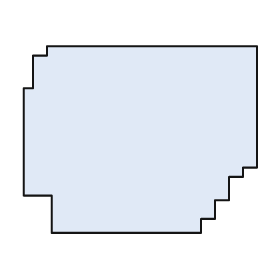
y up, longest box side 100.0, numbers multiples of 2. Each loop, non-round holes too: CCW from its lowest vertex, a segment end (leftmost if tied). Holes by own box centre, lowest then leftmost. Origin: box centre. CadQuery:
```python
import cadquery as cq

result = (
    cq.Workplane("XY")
    .moveTo(-38.0, -40.0)
    .lineTo(26.0, -40.0)
    .lineTo(26.0, -34.0)
    .lineTo(32.0, -34.0)
    .lineTo(32.0, -26.0)
    .lineTo(38.0, -26.0)
    .lineTo(38.0, -16.0)
    .lineTo(44.0, -16.0)
    .lineTo(44.0, -12.0)
    .lineTo(50.0, -12.0)
    .lineTo(50.0, 40.0)
    .lineTo(-40.0, 40.0)
    .lineTo(-40.0, 36.0)
    .lineTo(-46.0, 36.0)
    .lineTo(-46.0, 22.0)
    .lineTo(-50.0, 22.0)
    .lineTo(-50.0, -24.0)
    .lineTo(-38.0, -24.0)
    .close()
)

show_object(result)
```